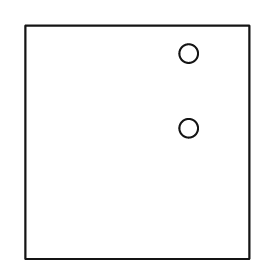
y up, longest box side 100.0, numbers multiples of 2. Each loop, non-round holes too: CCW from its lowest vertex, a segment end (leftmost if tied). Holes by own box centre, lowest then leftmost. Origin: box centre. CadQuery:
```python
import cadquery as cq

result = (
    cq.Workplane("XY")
    .moveTo(-48.0, -50.0)
    .lineTo(48.0, -50.0)
    .lineTo(48.0, 50.0)
    .lineTo(-48.0, 50.0)
    .close()
    .moveTo(22.0, 6.0)
    .circle(4.0)
    .moveTo(22.0, 38.0)
    .circle(4.0)
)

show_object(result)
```